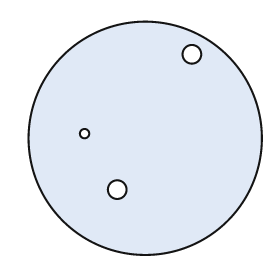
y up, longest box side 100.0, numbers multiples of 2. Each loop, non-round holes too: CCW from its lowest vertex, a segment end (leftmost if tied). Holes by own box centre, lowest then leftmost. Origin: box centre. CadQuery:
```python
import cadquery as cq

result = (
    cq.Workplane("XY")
    .moveTo(0.0, 0.0)
    .circle(50.0)
    .moveTo(-12.0, -22.0)
    .circle(4.0)
    .moveTo(-26.0, 2.0)
    .circle(2.0)
    .moveTo(20.0, 36.0)
    .circle(4.0)
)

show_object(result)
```